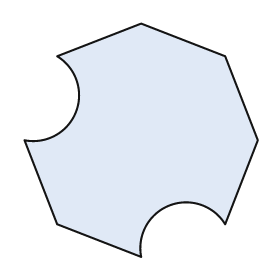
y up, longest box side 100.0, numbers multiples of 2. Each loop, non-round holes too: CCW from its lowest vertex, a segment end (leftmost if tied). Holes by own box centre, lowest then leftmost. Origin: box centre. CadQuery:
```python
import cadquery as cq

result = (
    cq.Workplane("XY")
    .moveTo(0.0, -50.0)
    .threePointArc((12.0, -28.0), (36.0, -36.0))
    .lineTo(50.0, 0.0)
    .lineTo(36.0, 36.0)
    .lineTo(0.0, 50.0)
    .lineTo(-36.0, 36.0)
    .threePointArc((-28.0, 12.0), (-50.0, 0.0))
    .lineTo(-36.0, -36.0)
    .close()
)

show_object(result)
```